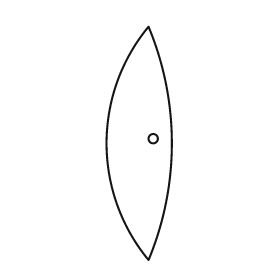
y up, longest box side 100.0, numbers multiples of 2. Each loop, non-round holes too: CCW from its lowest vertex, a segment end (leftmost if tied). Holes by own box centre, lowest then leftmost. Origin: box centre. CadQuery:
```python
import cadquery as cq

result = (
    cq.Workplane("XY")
    .moveTo(4.0, -50.0)
    .threePointArc((14.0, 0.0), (4.0, 50.0))
    .threePointArc((-14.0, 0.0), (4.0, -50.0))
    .close()
    .moveTo(6.0, 2.0)
    .circle(2.0)
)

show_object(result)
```